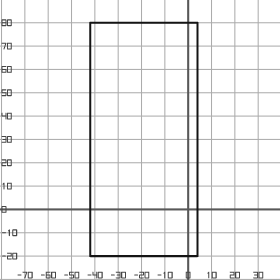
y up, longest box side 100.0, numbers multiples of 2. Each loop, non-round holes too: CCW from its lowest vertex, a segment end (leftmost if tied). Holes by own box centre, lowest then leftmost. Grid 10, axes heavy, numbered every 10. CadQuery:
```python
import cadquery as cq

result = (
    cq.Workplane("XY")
    .moveTo(-42.0, -20.0)
    .lineTo(4.0, -20.0)
    .lineTo(4.0, 80.0)
    .lineTo(-42.0, 80.0)
    .close()
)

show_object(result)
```